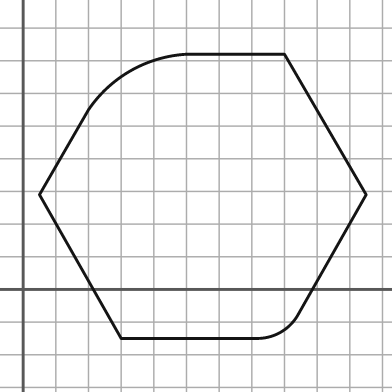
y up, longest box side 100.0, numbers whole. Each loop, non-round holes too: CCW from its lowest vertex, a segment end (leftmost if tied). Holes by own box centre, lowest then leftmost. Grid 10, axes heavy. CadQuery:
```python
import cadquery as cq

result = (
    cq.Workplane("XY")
    .moveTo(30.0, -15.0)
    .lineTo(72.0, -15.0)
    .threePointArc((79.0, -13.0), (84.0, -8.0))
    .lineTo(105.0, 29.0)
    .lineTo(80.0, 72.0)
    .lineTo(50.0, 72.0)
    .threePointArc((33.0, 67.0), (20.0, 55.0))
    .lineTo(5.0, 29.0)
    .close()
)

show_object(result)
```